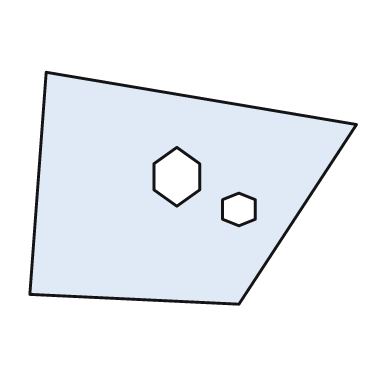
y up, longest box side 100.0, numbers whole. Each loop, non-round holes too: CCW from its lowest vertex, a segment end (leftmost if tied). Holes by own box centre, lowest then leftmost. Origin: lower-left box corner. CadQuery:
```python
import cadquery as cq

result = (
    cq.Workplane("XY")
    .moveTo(64.0, 0.0)
    .lineTo(100.0, 55.0)
    .lineTo(5.0, 71.0)
    .lineTo(0.0, 3.0)
    .close()
    .moveTo(64.0, 24.0)
    .lineTo(69.0, 26.0)
    .lineTo(69.0, 32.0)
    .lineTo(64.0, 34.0)
    .lineTo(59.0, 32.0)
    .lineTo(59.0, 26.0)
    .close()
    .moveTo(45.0, 30.0)
    .lineTo(52.0, 35.0)
    .lineTo(52.0, 43.0)
    .lineTo(45.0, 48.0)
    .lineTo(38.0, 43.0)
    .lineTo(38.0, 35.0)
    .close()
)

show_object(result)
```